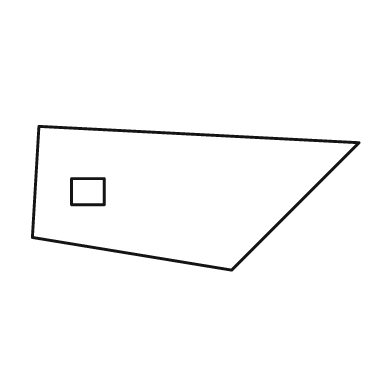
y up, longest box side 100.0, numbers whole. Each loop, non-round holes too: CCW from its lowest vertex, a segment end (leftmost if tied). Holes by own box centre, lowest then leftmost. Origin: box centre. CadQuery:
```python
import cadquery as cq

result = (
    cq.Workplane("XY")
    .moveTo(11.0, -22.0)
    .lineTo(50.0, 17.0)
    .lineTo(-48.0, 22.0)
    .lineTo(-50.0, -12.0)
    .close()
    .moveTo(-38.0, -2.0)
    .lineTo(-28.0, -2.0)
    .lineTo(-28.0, 6.0)
    .lineTo(-38.0, 6.0)
    .close()
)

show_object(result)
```